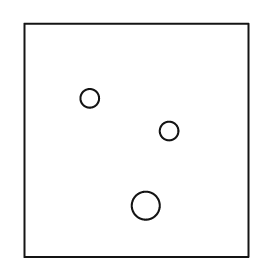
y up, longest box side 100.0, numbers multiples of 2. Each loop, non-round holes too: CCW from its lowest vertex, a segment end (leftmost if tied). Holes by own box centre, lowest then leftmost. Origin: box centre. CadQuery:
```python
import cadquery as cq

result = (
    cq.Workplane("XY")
    .moveTo(-48.0, -50.0)
    .lineTo(48.0, -50.0)
    .lineTo(48.0, 50.0)
    .lineTo(-48.0, 50.0)
    .close()
    .moveTo(4.0, -28.0)
    .circle(6.0)
    .moveTo(14.0, 4.0)
    .circle(4.0)
    .moveTo(-20.0, 18.0)
    .circle(4.0)
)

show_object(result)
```